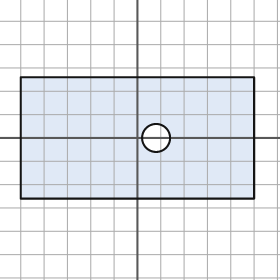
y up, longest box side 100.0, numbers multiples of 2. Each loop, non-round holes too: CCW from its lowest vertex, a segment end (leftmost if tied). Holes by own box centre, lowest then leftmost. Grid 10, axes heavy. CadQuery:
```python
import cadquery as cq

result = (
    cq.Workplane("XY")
    .moveTo(-50.0, -26.0)
    .lineTo(50.0, -26.0)
    .lineTo(50.0, 26.0)
    .lineTo(-50.0, 26.0)
    .close()
    .moveTo(8.0, 0.0)
    .circle(6.0)
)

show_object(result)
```